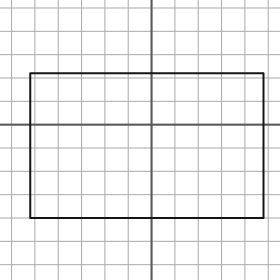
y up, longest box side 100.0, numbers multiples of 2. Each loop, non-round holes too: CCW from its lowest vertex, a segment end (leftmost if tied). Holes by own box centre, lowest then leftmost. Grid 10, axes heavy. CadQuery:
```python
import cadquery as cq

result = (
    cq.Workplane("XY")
    .moveTo(-52.0, -40.0)
    .lineTo(48.0, -40.0)
    .lineTo(48.0, 22.0)
    .lineTo(-52.0, 22.0)
    .close()
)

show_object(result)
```